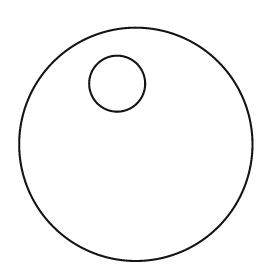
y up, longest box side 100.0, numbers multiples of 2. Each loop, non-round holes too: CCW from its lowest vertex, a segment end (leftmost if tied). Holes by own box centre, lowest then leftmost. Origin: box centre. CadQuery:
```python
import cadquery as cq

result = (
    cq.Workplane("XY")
    .moveTo(0.0, 0.0)
    .circle(50.0)
    .moveTo(-8.0, 26.0)
    .circle(12.0)
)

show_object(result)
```